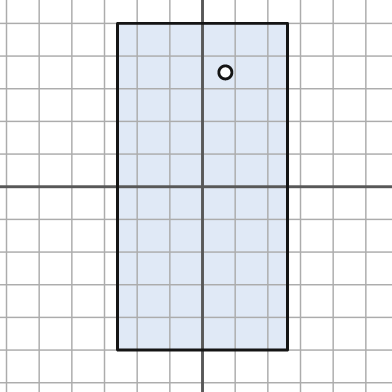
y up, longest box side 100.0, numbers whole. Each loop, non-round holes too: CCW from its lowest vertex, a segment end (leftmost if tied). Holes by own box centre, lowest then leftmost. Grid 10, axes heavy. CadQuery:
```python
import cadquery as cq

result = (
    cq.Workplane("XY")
    .moveTo(-26.0, -50.0)
    .lineTo(26.0, -50.0)
    .lineTo(26.0, 50.0)
    .lineTo(-26.0, 50.0)
    .close()
    .moveTo(7.0, 35.0)
    .circle(2.0)
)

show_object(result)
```